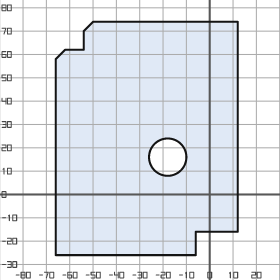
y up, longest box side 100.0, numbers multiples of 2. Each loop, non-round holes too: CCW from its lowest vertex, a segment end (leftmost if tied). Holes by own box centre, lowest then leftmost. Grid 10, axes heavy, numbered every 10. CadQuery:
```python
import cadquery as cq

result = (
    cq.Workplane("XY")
    .moveTo(-66.0, -26.0)
    .lineTo(-6.0, -26.0)
    .lineTo(-6.0, -16.0)
    .lineTo(12.0, -16.0)
    .lineTo(12.0, 74.0)
    .lineTo(-50.0, 74.0)
    .lineTo(-54.0, 70.0)
    .lineTo(-54.0, 62.0)
    .lineTo(-62.0, 62.0)
    .lineTo(-66.0, 58.0)
    .close()
    .moveTo(-18.0, 16.0)
    .circle(8.0)
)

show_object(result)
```